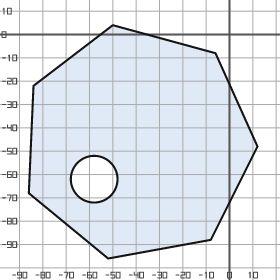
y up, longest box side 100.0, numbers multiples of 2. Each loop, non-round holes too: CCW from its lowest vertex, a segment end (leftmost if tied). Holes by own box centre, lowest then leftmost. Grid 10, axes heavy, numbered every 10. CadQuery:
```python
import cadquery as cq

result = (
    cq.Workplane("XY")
    .moveTo(-52.0, -96.0)
    .lineTo(-8.0, -88.0)
    .lineTo(12.0, -48.0)
    .lineTo(-6.0, -8.0)
    .lineTo(-50.0, 4.0)
    .lineTo(-84.0, -22.0)
    .lineTo(-86.0, -68.0)
    .close()
    .moveTo(-58.0, -62.0)
    .circle(10.0)
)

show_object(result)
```